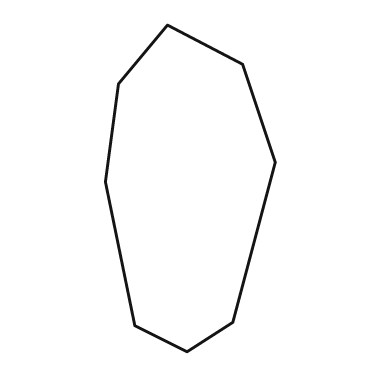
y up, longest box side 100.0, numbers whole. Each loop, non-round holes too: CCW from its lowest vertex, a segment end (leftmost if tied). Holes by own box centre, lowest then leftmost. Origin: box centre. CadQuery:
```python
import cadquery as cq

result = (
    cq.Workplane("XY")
    .moveTo(-1.0, -50.0)
    .lineTo(13.0, -41.0)
    .lineTo(26.0, 8.0)
    .lineTo(16.0, 38.0)
    .lineTo(-7.0, 50.0)
    .lineTo(-22.0, 32.0)
    .lineTo(-26.0, 2.0)
    .lineTo(-17.0, -42.0)
    .close()
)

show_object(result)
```